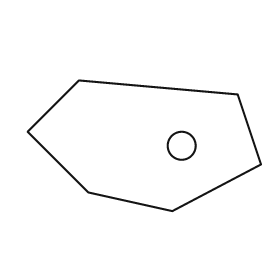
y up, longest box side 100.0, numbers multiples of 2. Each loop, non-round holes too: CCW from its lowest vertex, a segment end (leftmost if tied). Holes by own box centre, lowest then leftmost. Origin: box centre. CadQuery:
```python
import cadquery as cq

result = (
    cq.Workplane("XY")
    .moveTo(12.0, -28.0)
    .lineTo(50.0, -8.0)
    .lineTo(40.0, 22.0)
    .lineTo(-28.0, 28.0)
    .lineTo(-50.0, 6.0)
    .lineTo(-24.0, -20.0)
    .close()
    .moveTo(16.0, 0.0)
    .circle(6.0)
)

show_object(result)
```